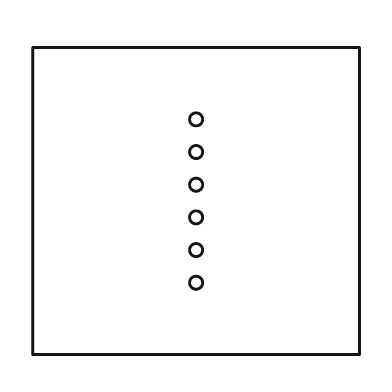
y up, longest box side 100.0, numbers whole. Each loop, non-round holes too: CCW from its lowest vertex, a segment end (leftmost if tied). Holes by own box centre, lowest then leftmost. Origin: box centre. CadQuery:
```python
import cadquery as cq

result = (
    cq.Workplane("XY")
    .moveTo(-50.0, -47.0)
    .lineTo(50.0, -47.0)
    .lineTo(50.0, 47.0)
    .lineTo(-50.0, 47.0)
    .close()
    .moveTo(0.0, -25.0)
    .circle(2.0)
    .moveTo(0.0, -15.0)
    .circle(2.0)
    .moveTo(0.0, -5.0)
    .circle(2.0)
    .moveTo(0.0, 5.0)
    .circle(2.0)
    .moveTo(0.0, 15.0)
    .circle(2.0)
    .moveTo(0.0, 25.0)
    .circle(2.0)
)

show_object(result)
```